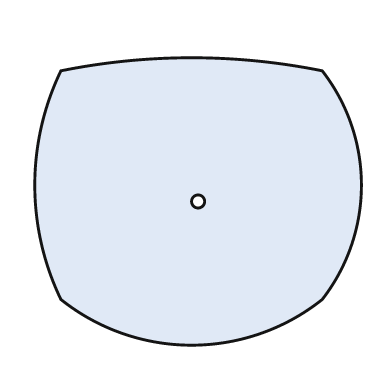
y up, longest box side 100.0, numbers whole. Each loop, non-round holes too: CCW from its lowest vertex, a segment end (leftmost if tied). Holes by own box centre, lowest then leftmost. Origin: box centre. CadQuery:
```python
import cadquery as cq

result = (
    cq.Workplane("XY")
    .moveTo(-42.0, -30.0)
    .threePointArc((-2.0, -44.0), (38.0, -30.0))
    .threePointArc((50.0, 5.0), (38.0, 40.0))
    .threePointArc((-2.0, 44.0), (-42.0, 40.0))
    .threePointArc((-50.0, 5.0), (-42.0, -30.0))
    .close()
    .moveTo(0.0, 0.0)
    .circle(2.0)
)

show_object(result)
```